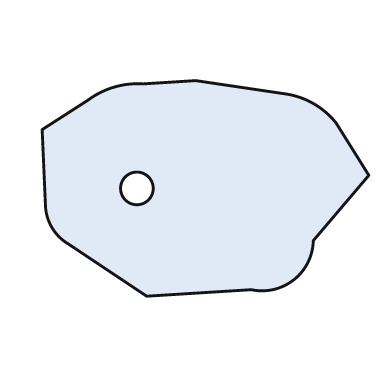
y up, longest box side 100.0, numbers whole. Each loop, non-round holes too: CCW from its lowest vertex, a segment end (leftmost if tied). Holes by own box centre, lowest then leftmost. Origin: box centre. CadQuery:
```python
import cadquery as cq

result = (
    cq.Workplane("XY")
    .moveTo(-18.0, -33.0)
    .lineTo(14.0, -31.0)
    .threePointArc((27.0, -28.0), (33.0, -16.0))
    .lineTo(50.0, 4.0)
    .lineTo(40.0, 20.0)
    .threePointArc((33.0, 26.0), (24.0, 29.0))
    .lineTo(-3.0, 33.0)
    .lineTo(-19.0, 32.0)
    .threePointArc((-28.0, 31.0), (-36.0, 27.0))
    .lineTo(-50.0, 18.0)
    .lineTo(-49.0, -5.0)
    .threePointArc((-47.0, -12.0), (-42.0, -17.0))
    .close()
    .moveTo(-21.0, 0.0)
    .circle(5.0)
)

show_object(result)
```